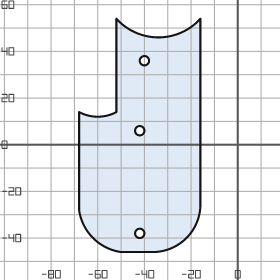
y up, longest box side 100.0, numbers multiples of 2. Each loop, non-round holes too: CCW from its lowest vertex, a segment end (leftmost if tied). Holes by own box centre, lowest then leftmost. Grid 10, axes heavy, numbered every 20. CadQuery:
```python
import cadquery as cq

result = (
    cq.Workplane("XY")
    .moveTo(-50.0, -46.0)
    .lineTo(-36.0, -46.0)
    .threePointArc((-22.0, -40.0), (-16.0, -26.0))
    .lineTo(-16.0, 54.0)
    .threePointArc((-34.0, 46.0), (-52.0, 54.0))
    .lineTo(-52.0, 14.0)
    .threePointArc((-60.0, 12.0), (-68.0, 14.0))
    .lineTo(-68.0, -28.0)
    .threePointArc((-62.0, -40.0), (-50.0, -46.0))
    .close()
    .moveTo(-42.0, -38.0)
    .circle(2.0)
    .moveTo(-42.0, 6.0)
    .circle(2.0)
    .moveTo(-40.0, 36.0)
    .circle(2.0)
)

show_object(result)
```